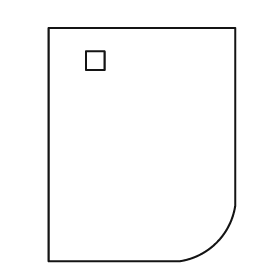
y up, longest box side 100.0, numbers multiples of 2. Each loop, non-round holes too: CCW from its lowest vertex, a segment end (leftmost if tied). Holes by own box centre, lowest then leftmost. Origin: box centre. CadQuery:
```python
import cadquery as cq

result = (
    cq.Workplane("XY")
    .moveTo(-40.0, -50.0)
    .lineTo(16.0, -50.0)
    .threePointArc((32.0, -42.0), (40.0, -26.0))
    .lineTo(40.0, 50.0)
    .lineTo(-40.0, 50.0)
    .close()
    .moveTo(-24.0, 32.0)
    .lineTo(-16.0, 32.0)
    .lineTo(-16.0, 40.0)
    .lineTo(-24.0, 40.0)
    .close()
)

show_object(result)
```